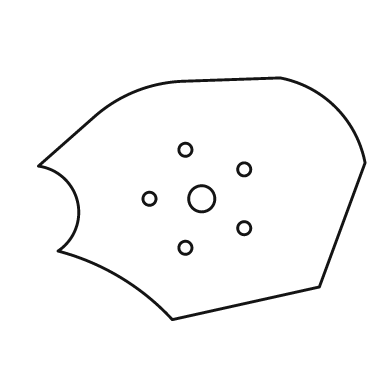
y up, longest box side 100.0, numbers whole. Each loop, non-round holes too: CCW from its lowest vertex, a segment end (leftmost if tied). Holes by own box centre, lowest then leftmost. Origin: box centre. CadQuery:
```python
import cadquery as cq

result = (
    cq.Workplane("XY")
    .moveTo(-9.0, -37.0)
    .lineTo(36.0, -27.0)
    .lineTo(50.0, 11.0)
    .threePointArc((41.0, 28.0), (24.0, 37.0))
    .lineTo(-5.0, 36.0)
    .threePointArc((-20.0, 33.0), (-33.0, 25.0))
    .lineTo(-50.0, 10.0)
    .threePointArc((-38.0, -1.0), (-44.0, -16.0))
    .threePointArc((-25.0, -24.0), (-9.0, -37.0))
    .close()
    .moveTo(-5.0, -15.0)
    .circle(2.0)
    .moveTo(13.0, -9.0)
    .circle(2.0)
    .moveTo(-16.0, 0.0)
    .circle(2.0)
    .moveTo(0.0, 0.0)
    .circle(4.0)
    .moveTo(13.0, 9.0)
    .circle(2.0)
    .moveTo(-5.0, 15.0)
    .circle(2.0)
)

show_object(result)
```